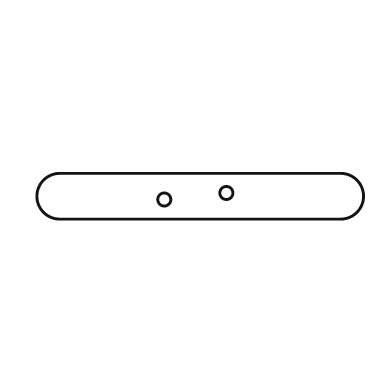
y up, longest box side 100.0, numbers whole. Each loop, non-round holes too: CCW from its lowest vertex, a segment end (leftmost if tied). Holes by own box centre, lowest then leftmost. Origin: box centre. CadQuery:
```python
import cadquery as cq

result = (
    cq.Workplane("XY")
    .moveTo(-43.0, -7.0)
    .lineTo(43.0, -7.0)
    .threePointArc((50.0, 0.0), (43.0, 7.0))
    .lineTo(-43.0, 7.0)
    .threePointArc((-50.0, 0.0), (-43.0, -7.0))
    .close()
    .moveTo(-11.0, -1.0)
    .circle(2.0)
    .moveTo(8.0, 1.0)
    .circle(2.0)
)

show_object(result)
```